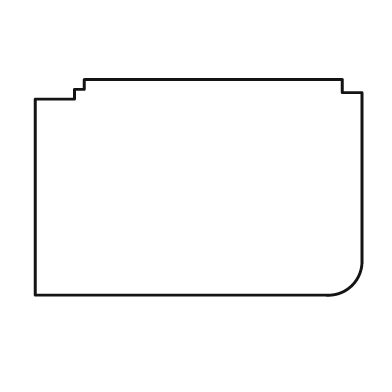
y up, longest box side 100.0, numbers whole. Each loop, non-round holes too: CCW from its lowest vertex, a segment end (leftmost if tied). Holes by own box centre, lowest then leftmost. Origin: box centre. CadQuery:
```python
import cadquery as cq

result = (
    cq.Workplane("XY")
    .moveTo(-50.0, -33.0)
    .lineTo(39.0, -33.0)
    .threePointArc((47.0, -30.0), (50.0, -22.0))
    .lineTo(50.0, 29.0)
    .lineTo(44.0, 29.0)
    .lineTo(44.0, 33.0)
    .lineTo(-35.0, 33.0)
    .lineTo(-35.0, 30.0)
    .lineTo(-38.0, 30.0)
    .lineTo(-38.0, 27.0)
    .lineTo(-50.0, 27.0)
    .close()
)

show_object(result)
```